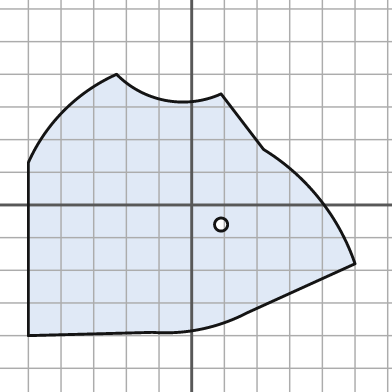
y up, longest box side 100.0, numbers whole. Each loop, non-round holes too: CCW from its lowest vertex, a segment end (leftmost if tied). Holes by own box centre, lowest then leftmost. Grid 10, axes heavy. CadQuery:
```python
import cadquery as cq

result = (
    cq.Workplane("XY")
    .moveTo(-50.0, -40.0)
    .lineTo(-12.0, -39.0)
    .threePointArc((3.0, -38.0), (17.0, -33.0))
    .lineTo(50.0, -18.0)
    .threePointArc((39.0, 2.0), (22.0, 17.0))
    .lineTo(9.0, 34.0)
    .threePointArc((-8.0, 32.0), (-23.0, 40.0))
    .threePointArc((-39.0, 29.0), (-50.0, 13.0))
    .close()
    .moveTo(9.0, -6.0)
    .circle(2.0)
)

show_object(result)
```